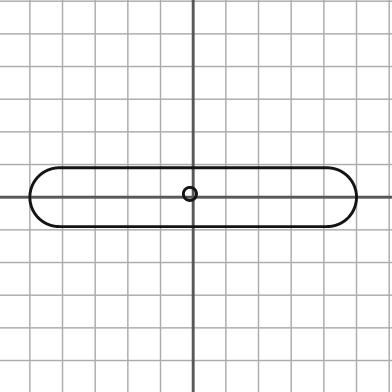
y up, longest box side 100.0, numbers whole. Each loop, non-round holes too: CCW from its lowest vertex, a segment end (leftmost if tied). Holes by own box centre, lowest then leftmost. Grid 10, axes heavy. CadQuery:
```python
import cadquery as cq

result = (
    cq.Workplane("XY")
    .moveTo(-41.0, -9.0)
    .lineTo(41.0, -9.0)
    .threePointArc((50.0, 0.0), (41.0, 9.0))
    .lineTo(-41.0, 9.0)
    .threePointArc((-50.0, 0.0), (-41.0, -9.0))
    .close()
    .moveTo(-1.0, 1.0)
    .circle(2.0)
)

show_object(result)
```